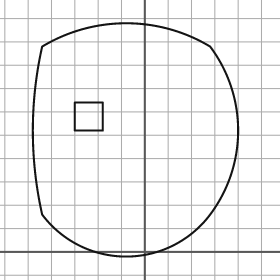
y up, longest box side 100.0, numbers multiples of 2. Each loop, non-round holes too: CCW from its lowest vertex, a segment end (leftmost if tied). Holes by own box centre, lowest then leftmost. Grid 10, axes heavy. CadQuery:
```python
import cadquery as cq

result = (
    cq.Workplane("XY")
    .moveTo(-44.0, 16.0)
    .threePointArc((-8.0, -2.0), (28.0, 16.0))
    .threePointArc((40.0, 52.0), (28.0, 88.0))
    .threePointArc((-8.0, 98.0), (-44.0, 88.0))
    .threePointArc((-48.0, 52.0), (-44.0, 16.0))
    .close()
    .moveTo(-30.0, 52.0)
    .lineTo(-18.0, 52.0)
    .lineTo(-18.0, 64.0)
    .lineTo(-30.0, 64.0)
    .close()
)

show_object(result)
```